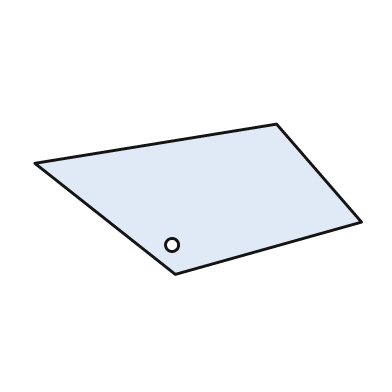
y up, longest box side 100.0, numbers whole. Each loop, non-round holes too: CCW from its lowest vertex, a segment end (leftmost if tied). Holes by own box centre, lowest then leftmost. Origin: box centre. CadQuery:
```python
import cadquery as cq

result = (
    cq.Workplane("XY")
    .moveTo(-7.0, -23.0)
    .lineTo(50.0, -7.0)
    .lineTo(24.0, 23.0)
    .lineTo(-50.0, 11.0)
    .close()
    .moveTo(-8.0, -14.0)
    .circle(2.0)
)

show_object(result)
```